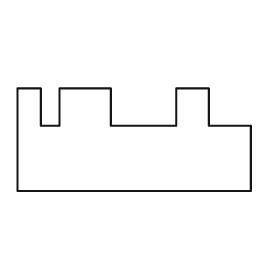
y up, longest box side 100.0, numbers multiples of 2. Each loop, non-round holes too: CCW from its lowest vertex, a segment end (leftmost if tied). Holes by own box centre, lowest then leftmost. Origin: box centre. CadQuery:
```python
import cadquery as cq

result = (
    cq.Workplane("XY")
    .moveTo(-50.0, -22.0)
    .lineTo(50.0, -22.0)
    .lineTo(50.0, 6.0)
    .lineTo(32.0, 6.0)
    .lineTo(32.0, 22.0)
    .lineTo(18.0, 22.0)
    .lineTo(18.0, 6.0)
    .lineTo(-10.0, 6.0)
    .lineTo(-10.0, 22.0)
    .lineTo(-32.0, 22.0)
    .lineTo(-32.0, 6.0)
    .lineTo(-40.0, 6.0)
    .lineTo(-40.0, 22.0)
    .lineTo(-50.0, 22.0)
    .close()
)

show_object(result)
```